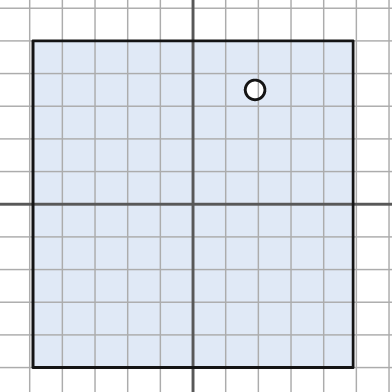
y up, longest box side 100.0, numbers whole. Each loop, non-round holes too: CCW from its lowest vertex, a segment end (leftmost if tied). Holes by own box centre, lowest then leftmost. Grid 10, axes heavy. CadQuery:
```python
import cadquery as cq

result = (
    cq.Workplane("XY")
    .moveTo(-49.0, -50.0)
    .lineTo(49.0, -50.0)
    .lineTo(49.0, 50.0)
    .lineTo(-49.0, 50.0)
    .close()
    .moveTo(19.0, 35.0)
    .circle(3.0)
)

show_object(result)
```